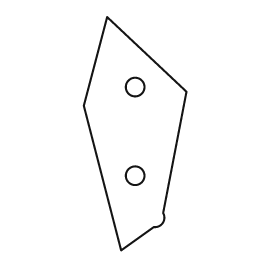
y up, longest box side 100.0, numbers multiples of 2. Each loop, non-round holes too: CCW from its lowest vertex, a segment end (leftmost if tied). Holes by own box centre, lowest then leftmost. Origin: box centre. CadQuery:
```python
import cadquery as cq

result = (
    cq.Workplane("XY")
    .moveTo(-6.0, -50.0)
    .lineTo(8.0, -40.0)
    .threePointArc((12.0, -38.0), (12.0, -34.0))
    .lineTo(22.0, 18.0)
    .lineTo(-12.0, 50.0)
    .lineTo(-22.0, 12.0)
    .close()
    .moveTo(0.0, -18.0)
    .circle(4.0)
    .moveTo(0.0, 20.0)
    .circle(4.0)
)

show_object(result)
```